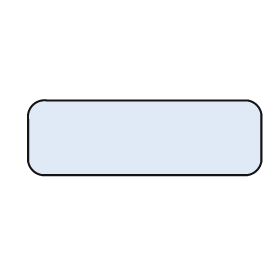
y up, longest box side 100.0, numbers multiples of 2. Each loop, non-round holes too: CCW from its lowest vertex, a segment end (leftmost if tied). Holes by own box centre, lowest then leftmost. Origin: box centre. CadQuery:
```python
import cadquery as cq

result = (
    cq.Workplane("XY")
    .moveTo(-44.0, -16.0)
    .lineTo(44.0, -16.0)
    .threePointArc((48.0, -14.0), (50.0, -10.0))
    .lineTo(50.0, 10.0)
    .threePointArc((48.0, 14.0), (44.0, 16.0))
    .lineTo(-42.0, 16.0)
    .threePointArc((-48.0, 14.0), (-50.0, 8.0))
    .lineTo(-50.0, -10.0)
    .threePointArc((-48.0, -14.0), (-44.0, -16.0))
    .close()
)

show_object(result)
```